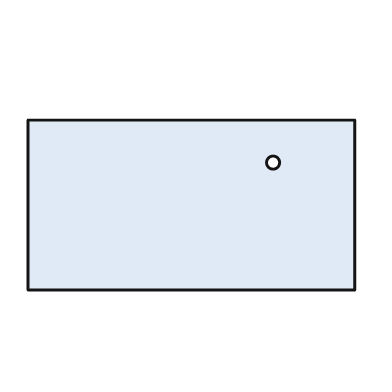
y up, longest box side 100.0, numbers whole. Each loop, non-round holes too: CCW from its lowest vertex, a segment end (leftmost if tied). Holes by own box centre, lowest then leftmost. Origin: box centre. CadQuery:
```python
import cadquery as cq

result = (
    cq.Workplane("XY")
    .moveTo(-50.0, -26.0)
    .lineTo(50.0, -26.0)
    .lineTo(50.0, 26.0)
    .lineTo(-50.0, 26.0)
    .close()
    .moveTo(25.0, 13.0)
    .circle(2.0)
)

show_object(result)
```